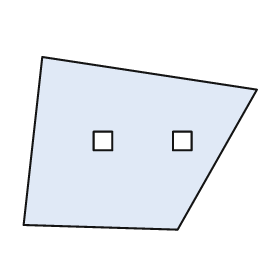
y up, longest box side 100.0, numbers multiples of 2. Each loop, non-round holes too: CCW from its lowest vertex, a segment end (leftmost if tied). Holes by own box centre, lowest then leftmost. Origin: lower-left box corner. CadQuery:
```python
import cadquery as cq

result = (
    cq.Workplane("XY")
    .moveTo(66.0, 0.0)
    .lineTo(100.0, 60.0)
    .lineTo(8.0, 74.0)
    .lineTo(0.0, 2.0)
    .close()
    .moveTo(30.0, 34.0)
    .lineTo(38.0, 34.0)
    .lineTo(38.0, 42.0)
    .lineTo(30.0, 42.0)
    .close()
    .moveTo(64.0, 34.0)
    .lineTo(72.0, 34.0)
    .lineTo(72.0, 42.0)
    .lineTo(64.0, 42.0)
    .close()
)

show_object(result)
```